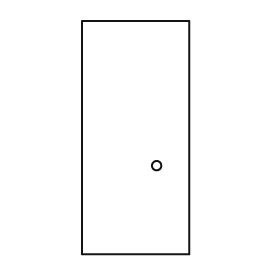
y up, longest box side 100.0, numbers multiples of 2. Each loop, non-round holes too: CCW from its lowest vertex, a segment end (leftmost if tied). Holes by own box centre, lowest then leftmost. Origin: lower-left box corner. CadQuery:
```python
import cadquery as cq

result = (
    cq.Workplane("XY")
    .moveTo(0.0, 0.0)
    .lineTo(46.0, 0.0)
    .lineTo(46.0, 100.0)
    .lineTo(0.0, 100.0)
    .close()
    .moveTo(32.0, 38.0)
    .circle(2.0)
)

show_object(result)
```